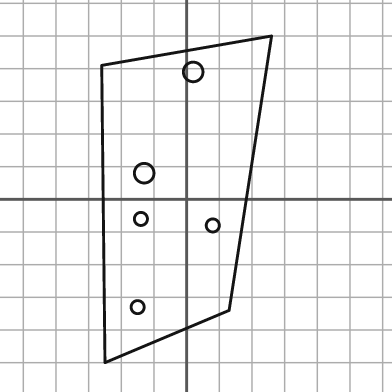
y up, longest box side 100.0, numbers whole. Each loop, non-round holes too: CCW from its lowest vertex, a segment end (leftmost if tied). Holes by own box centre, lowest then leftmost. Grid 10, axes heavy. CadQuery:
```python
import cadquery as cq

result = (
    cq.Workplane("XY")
    .moveTo(-25.0, -50.0)
    .lineTo(13.0, -34.0)
    .lineTo(26.0, 50.0)
    .lineTo(-26.0, 41.0)
    .close()
    .moveTo(-15.0, -33.0)
    .circle(2.0)
    .moveTo(8.0, -8.0)
    .circle(2.0)
    .moveTo(-14.0, -6.0)
    .circle(2.0)
    .moveTo(-13.0, 8.0)
    .circle(3.0)
    .moveTo(2.0, 39.0)
    .circle(3.0)
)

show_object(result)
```